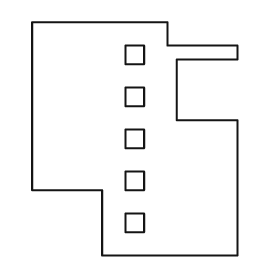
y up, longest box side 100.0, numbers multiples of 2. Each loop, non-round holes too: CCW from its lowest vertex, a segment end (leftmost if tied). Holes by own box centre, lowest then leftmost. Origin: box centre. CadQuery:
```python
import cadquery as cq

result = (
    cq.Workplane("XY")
    .moveTo(-14.0, -50.0)
    .lineTo(44.0, -50.0)
    .lineTo(44.0, 8.0)
    .lineTo(18.0, 8.0)
    .lineTo(18.0, 34.0)
    .lineTo(44.0, 34.0)
    .lineTo(44.0, 40.0)
    .lineTo(14.0, 40.0)
    .lineTo(14.0, 50.0)
    .lineTo(-44.0, 50.0)
    .lineTo(-44.0, -22.0)
    .lineTo(-14.0, -22.0)
    .close()
    .moveTo(-4.0, -40.0)
    .lineTo(4.0, -40.0)
    .lineTo(4.0, -32.0)
    .lineTo(-4.0, -32.0)
    .close()
    .moveTo(-4.0, -22.0)
    .lineTo(4.0, -22.0)
    .lineTo(4.0, -14.0)
    .lineTo(-4.0, -14.0)
    .close()
    .moveTo(-4.0, -4.0)
    .lineTo(4.0, -4.0)
    .lineTo(4.0, 4.0)
    .lineTo(-4.0, 4.0)
    .close()
    .moveTo(-4.0, 14.0)
    .lineTo(4.0, 14.0)
    .lineTo(4.0, 22.0)
    .lineTo(-4.0, 22.0)
    .close()
    .moveTo(-4.0, 32.0)
    .lineTo(4.0, 32.0)
    .lineTo(4.0, 40.0)
    .lineTo(-4.0, 40.0)
    .close()
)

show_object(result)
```